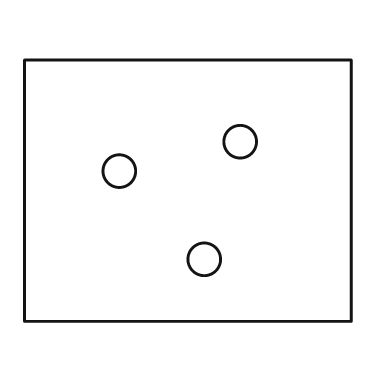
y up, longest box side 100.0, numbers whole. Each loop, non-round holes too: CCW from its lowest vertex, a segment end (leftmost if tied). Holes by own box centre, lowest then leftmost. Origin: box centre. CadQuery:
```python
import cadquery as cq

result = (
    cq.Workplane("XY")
    .moveTo(-50.0, -40.0)
    .lineTo(50.0, -40.0)
    .lineTo(50.0, 40.0)
    .lineTo(-50.0, 40.0)
    .close()
    .moveTo(5.0, -21.0)
    .circle(5.0)
    .moveTo(-21.0, 6.0)
    .circle(5.0)
    .moveTo(16.0, 15.0)
    .circle(5.0)
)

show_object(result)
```